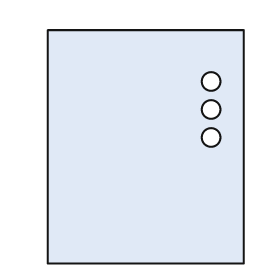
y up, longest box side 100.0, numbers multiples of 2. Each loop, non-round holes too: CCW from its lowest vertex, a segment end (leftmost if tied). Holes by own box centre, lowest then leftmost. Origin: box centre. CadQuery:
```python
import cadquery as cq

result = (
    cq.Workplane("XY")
    .moveTo(-42.0, -50.0)
    .lineTo(42.0, -50.0)
    .lineTo(42.0, 50.0)
    .lineTo(-42.0, 50.0)
    .close()
    .moveTo(28.0, 4.0)
    .circle(4.0)
    .moveTo(28.0, 16.0)
    .circle(4.0)
    .moveTo(28.0, 28.0)
    .circle(4.0)
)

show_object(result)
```